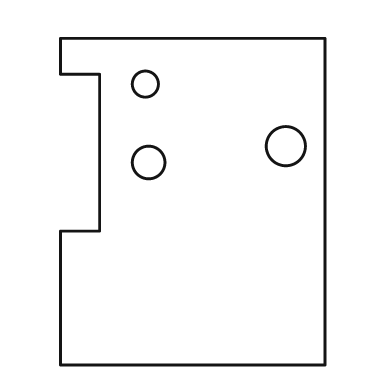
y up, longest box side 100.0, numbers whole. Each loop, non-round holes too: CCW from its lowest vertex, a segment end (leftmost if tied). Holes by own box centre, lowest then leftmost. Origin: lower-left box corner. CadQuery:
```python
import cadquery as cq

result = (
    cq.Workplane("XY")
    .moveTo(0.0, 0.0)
    .lineTo(81.0, 0.0)
    .lineTo(81.0, 100.0)
    .lineTo(0.0, 100.0)
    .lineTo(0.0, 89.0)
    .lineTo(12.0, 89.0)
    .lineTo(12.0, 41.0)
    .lineTo(0.0, 41.0)
    .close()
    .moveTo(27.0, 62.0)
    .circle(5.0)
    .moveTo(69.0, 67.0)
    .circle(6.0)
    .moveTo(26.0, 86.0)
    .circle(4.0)
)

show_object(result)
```